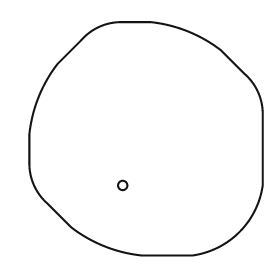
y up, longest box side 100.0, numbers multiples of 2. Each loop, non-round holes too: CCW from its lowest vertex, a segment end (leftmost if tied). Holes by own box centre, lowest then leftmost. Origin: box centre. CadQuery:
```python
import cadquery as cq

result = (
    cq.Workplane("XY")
    .moveTo(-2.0, -50.0)
    .lineTo(20.0, -50.0)
    .threePointArc((40.0, -40.0), (50.0, -20.0))
    .lineTo(50.0, 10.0)
    .threePointArc((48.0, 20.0), (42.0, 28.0))
    .lineTo(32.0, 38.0)
    .threePointArc((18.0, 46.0), (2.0, 50.0))
    .lineTo(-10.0, 50.0)
    .threePointArc((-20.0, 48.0), (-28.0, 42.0))
    .lineTo(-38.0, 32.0)
    .threePointArc((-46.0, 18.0), (-50.0, 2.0))
    .lineTo(-50.0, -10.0)
    .threePointArc((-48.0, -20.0), (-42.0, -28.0))
    .lineTo(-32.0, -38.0)
    .threePointArc((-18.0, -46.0), (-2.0, -50.0))
    .close()
    .moveTo(-10.0, -20.0)
    .circle(2.0)
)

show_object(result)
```